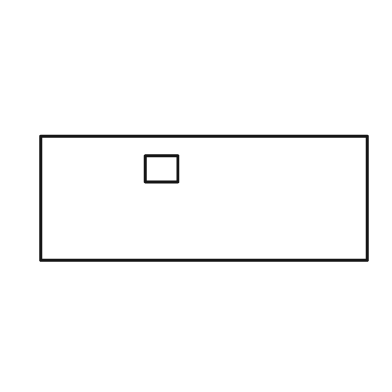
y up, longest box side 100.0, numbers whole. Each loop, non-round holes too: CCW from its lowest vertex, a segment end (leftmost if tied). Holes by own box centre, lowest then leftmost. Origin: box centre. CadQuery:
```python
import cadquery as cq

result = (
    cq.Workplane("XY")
    .moveTo(-50.0, -19.0)
    .lineTo(50.0, -19.0)
    .lineTo(50.0, 19.0)
    .lineTo(-50.0, 19.0)
    .close()
    .moveTo(-18.0, 5.0)
    .lineTo(-8.0, 5.0)
    .lineTo(-8.0, 13.0)
    .lineTo(-18.0, 13.0)
    .close()
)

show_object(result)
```